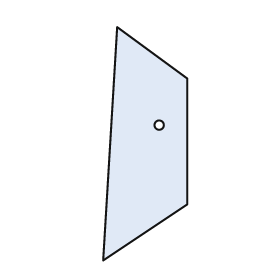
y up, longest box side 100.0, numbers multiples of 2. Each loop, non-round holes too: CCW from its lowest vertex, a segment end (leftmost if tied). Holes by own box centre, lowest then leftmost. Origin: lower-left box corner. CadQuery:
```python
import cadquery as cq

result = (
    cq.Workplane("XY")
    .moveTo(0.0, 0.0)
    .lineTo(36.0, 24.0)
    .lineTo(36.0, 78.0)
    .lineTo(6.0, 100.0)
    .close()
    .moveTo(24.0, 58.0)
    .circle(2.0)
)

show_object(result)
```